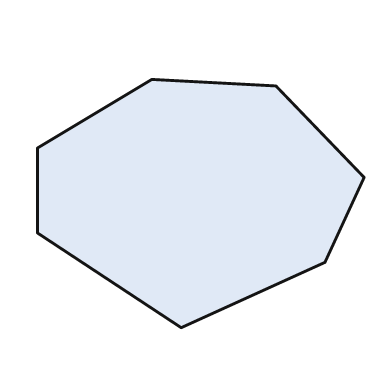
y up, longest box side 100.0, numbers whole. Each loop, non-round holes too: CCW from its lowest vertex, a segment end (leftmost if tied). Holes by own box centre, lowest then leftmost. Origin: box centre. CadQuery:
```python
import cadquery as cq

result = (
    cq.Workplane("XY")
    .moveTo(-6.0, -38.0)
    .lineTo(38.0, -18.0)
    .lineTo(50.0, 8.0)
    .lineTo(23.0, 36.0)
    .lineTo(-15.0, 38.0)
    .lineTo(-50.0, 17.0)
    .lineTo(-50.0, -9.0)
    .close()
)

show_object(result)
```